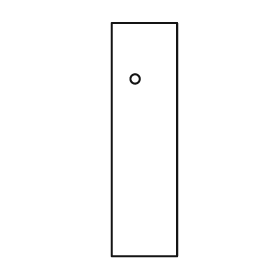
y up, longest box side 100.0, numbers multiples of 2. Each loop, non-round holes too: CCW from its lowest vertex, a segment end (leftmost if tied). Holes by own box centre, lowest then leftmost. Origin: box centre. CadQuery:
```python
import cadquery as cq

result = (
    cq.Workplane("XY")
    .moveTo(-14.0, -50.0)
    .lineTo(14.0, -50.0)
    .lineTo(14.0, 50.0)
    .lineTo(-14.0, 50.0)
    .close()
    .moveTo(-4.0, 26.0)
    .circle(2.0)
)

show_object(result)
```